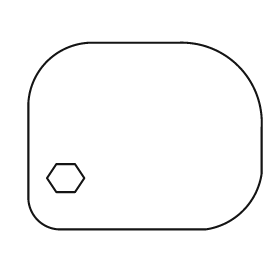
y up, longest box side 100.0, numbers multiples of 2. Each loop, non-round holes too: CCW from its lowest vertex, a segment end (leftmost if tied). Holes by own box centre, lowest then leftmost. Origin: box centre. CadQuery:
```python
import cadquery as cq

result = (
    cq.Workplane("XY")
    .moveTo(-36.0, -40.0)
    .lineTo(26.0, -40.0)
    .threePointArc((42.0, -32.0), (50.0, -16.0))
    .lineTo(50.0, 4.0)
    .threePointArc((40.0, 30.0), (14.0, 40.0))
    .lineTo(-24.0, 40.0)
    .threePointArc((-42.0, 32.0), (-50.0, 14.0))
    .lineTo(-50.0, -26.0)
    .threePointArc((-46.0, -36.0), (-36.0, -40.0))
    .close()
    .moveTo(-38.0, -24.0)
    .lineTo(-30.0, -24.0)
    .lineTo(-26.0, -18.0)
    .lineTo(-30.0, -12.0)
    .lineTo(-38.0, -12.0)
    .lineTo(-42.0, -18.0)
    .close()
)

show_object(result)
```